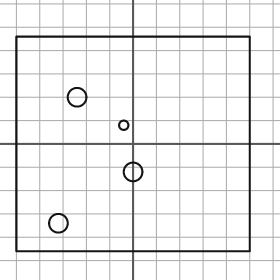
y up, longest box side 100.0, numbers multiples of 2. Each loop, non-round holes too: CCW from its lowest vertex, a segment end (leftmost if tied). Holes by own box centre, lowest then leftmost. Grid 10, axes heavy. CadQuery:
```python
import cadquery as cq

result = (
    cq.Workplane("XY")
    .moveTo(-50.0, -46.0)
    .lineTo(50.0, -46.0)
    .lineTo(50.0, 46.0)
    .lineTo(-50.0, 46.0)
    .close()
    .moveTo(-32.0, -34.0)
    .circle(4.0)
    .moveTo(0.0, -12.0)
    .circle(4.0)
    .moveTo(-4.0, 8.0)
    .circle(2.0)
    .moveTo(-24.0, 20.0)
    .circle(4.0)
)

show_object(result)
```